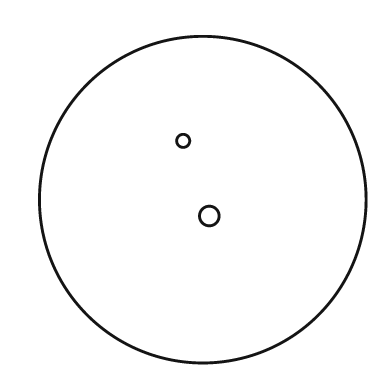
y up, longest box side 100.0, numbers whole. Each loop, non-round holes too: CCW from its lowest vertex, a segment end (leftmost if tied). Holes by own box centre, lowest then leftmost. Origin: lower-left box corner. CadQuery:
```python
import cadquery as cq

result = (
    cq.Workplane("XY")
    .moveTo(50.0, 50.0)
    .circle(50.0)
    .moveTo(52.0, 45.0)
    .circle(3.0)
    .moveTo(44.0, 68.0)
    .circle(2.0)
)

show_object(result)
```